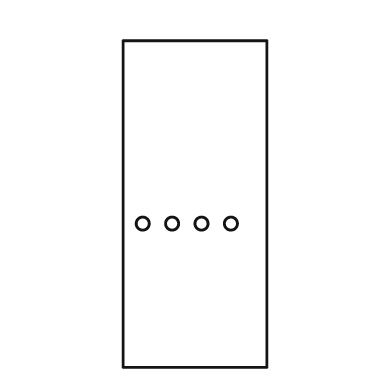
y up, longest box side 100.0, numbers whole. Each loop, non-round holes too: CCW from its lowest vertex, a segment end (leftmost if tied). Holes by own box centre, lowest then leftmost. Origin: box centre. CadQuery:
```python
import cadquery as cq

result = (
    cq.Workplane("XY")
    .moveTo(-22.0, -50.0)
    .lineTo(22.0, -50.0)
    .lineTo(22.0, 50.0)
    .lineTo(-22.0, 50.0)
    .close()
    .moveTo(-16.0, -6.0)
    .circle(2.0)
    .moveTo(-7.0, -6.0)
    .circle(2.0)
    .moveTo(2.0, -6.0)
    .circle(2.0)
    .moveTo(11.0, -6.0)
    .circle(2.0)
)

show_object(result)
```